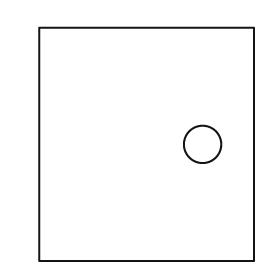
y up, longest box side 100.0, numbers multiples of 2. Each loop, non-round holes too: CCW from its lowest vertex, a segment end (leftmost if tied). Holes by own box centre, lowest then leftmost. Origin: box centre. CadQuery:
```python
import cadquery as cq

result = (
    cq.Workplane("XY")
    .moveTo(-46.0, -50.0)
    .lineTo(46.0, -50.0)
    .lineTo(46.0, 50.0)
    .lineTo(-46.0, 50.0)
    .close()
    .moveTo(24.0, 0.0)
    .circle(8.0)
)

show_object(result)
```